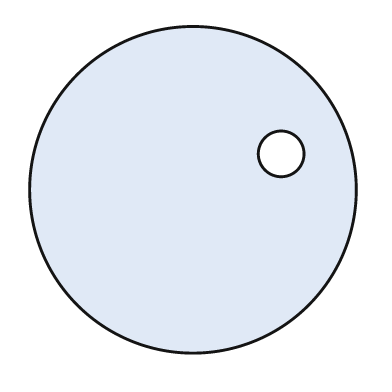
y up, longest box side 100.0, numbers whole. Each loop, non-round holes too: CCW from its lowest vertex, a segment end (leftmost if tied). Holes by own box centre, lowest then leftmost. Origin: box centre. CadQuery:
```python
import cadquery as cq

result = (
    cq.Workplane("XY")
    .moveTo(0.0, 0.0)
    .circle(50.0)
    .moveTo(27.0, 11.0)
    .circle(7.0)
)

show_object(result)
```